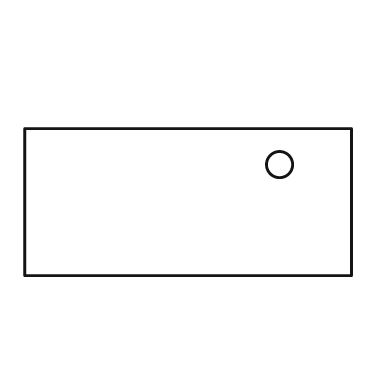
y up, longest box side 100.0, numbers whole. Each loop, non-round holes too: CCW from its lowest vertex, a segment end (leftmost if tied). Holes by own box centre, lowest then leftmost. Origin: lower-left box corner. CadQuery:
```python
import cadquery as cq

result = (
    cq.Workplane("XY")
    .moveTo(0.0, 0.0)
    .lineTo(100.0, 0.0)
    .lineTo(100.0, 45.0)
    .lineTo(0.0, 45.0)
    .close()
    .moveTo(78.0, 34.0)
    .circle(4.0)
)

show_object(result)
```